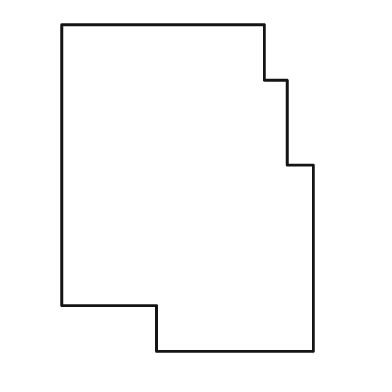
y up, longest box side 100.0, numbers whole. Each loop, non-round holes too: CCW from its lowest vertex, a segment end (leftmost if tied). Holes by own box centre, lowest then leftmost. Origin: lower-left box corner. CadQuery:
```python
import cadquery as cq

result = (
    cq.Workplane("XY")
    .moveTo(29.0, 0.0)
    .lineTo(77.0, 0.0)
    .lineTo(77.0, 57.0)
    .lineTo(69.0, 57.0)
    .lineTo(69.0, 83.0)
    .lineTo(62.0, 83.0)
    .lineTo(62.0, 100.0)
    .lineTo(0.0, 100.0)
    .lineTo(0.0, 14.0)
    .lineTo(29.0, 14.0)
    .close()
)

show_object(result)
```